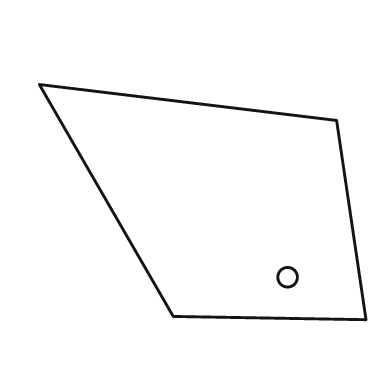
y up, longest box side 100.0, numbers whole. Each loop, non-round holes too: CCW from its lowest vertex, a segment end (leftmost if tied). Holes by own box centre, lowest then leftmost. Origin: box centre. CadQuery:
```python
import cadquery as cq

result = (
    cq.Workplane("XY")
    .moveTo(50.0, -36.0)
    .lineTo(41.0, 25.0)
    .lineTo(-50.0, 36.0)
    .lineTo(-9.0, -35.0)
    .close()
    .moveTo(26.0, -23.0)
    .circle(3.0)
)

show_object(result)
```